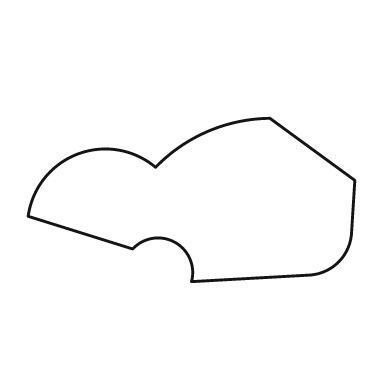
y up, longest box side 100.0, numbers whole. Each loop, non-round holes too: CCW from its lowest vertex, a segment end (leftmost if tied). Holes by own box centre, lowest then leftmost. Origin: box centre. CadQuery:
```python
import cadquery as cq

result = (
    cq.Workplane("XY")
    .moveTo(0.0, -25.0)
    .lineTo(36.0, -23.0)
    .threePointArc((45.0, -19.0), (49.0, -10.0))
    .lineTo(50.0, 6.0)
    .lineTo(24.0, 25.0)
    .threePointArc((5.0, 21.0), (-11.0, 10.0))
    .threePointArc((-35.0, 14.0), (-50.0, -5.0))
    .lineTo(-18.0, -15.0)
    .threePointArc((-5.0, -13.0), (0.0, -25.0))
    .close()
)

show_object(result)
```